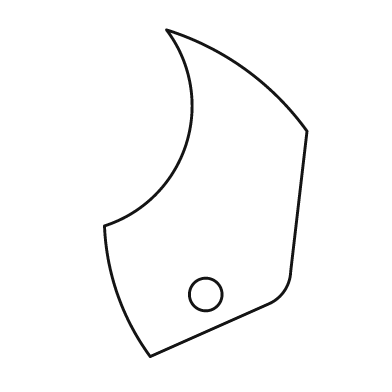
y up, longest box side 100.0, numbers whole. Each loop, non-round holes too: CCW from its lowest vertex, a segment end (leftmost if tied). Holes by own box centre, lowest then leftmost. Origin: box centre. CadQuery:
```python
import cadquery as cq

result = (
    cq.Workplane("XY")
    .moveTo(-17.0, -50.0)
    .lineTo(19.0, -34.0)
    .threePointArc((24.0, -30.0), (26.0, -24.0))
    .lineTo(31.0, 19.0)
    .threePointArc((12.0, 38.0), (-12.0, 50.0))
    .threePointArc((-6.0, 15.0), (-31.0, -10.0))
    .threePointArc((-27.0, -31.0), (-17.0, -50.0))
    .close()
    .moveTo(0.0, -31.0)
    .circle(5.0)
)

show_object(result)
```